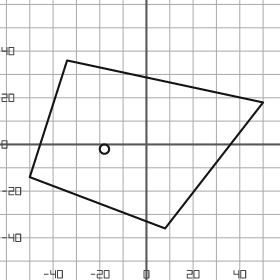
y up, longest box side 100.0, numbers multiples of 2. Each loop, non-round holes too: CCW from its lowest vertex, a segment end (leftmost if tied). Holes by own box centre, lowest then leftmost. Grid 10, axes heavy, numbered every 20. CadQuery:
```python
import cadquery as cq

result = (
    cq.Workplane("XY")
    .moveTo(8.0, -36.0)
    .lineTo(50.0, 18.0)
    .lineTo(-34.0, 36.0)
    .lineTo(-50.0, -14.0)
    .close()
    .moveTo(-18.0, -2.0)
    .circle(2.0)
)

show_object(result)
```